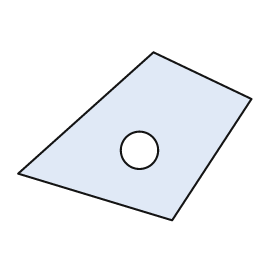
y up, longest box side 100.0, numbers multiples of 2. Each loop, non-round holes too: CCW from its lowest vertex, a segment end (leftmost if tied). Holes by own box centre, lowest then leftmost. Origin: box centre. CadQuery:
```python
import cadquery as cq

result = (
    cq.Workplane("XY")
    .moveTo(16.0, -36.0)
    .lineTo(50.0, 16.0)
    .lineTo(8.0, 36.0)
    .lineTo(-50.0, -16.0)
    .close()
    .moveTo(2.0, -6.0)
    .circle(8.0)
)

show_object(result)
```